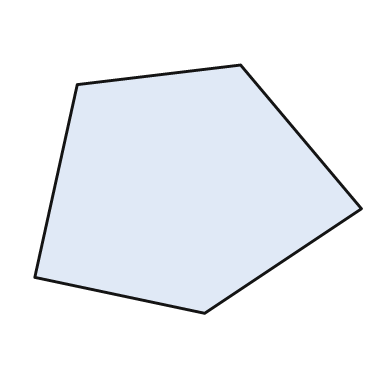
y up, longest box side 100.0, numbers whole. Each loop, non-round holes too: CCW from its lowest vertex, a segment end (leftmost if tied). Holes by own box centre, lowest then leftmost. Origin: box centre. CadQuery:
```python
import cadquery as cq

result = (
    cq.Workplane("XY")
    .moveTo(2.0, -38.0)
    .lineTo(50.0, -6.0)
    .lineTo(13.0, 38.0)
    .lineTo(-37.0, 32.0)
    .lineTo(-50.0, -27.0)
    .close()
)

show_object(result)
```